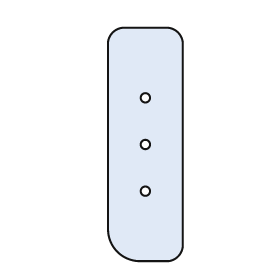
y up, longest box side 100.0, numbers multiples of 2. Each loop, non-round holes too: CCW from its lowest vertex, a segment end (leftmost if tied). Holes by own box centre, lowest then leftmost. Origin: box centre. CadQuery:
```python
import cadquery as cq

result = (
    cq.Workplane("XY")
    .moveTo(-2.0, -50.0)
    .lineTo(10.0, -50.0)
    .threePointArc((14.0, -48.0), (16.0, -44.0))
    .lineTo(16.0, 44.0)
    .threePointArc((14.0, 48.0), (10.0, 50.0))
    .lineTo(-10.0, 50.0)
    .threePointArc((-14.0, 48.0), (-16.0, 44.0))
    .lineTo(-16.0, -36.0)
    .threePointArc((-12.0, -46.0), (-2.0, -50.0))
    .close()
    .moveTo(0.0, -20.0)
    .circle(2.0)
    .moveTo(0.0, 0.0)
    .circle(2.0)
    .moveTo(0.0, 20.0)
    .circle(2.0)
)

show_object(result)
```